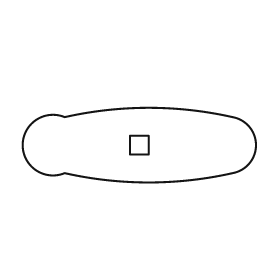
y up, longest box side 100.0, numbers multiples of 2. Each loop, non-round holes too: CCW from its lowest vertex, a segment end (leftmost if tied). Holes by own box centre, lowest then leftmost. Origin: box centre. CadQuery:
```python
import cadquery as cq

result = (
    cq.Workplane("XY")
    .moveTo(-32.0, -12.0)
    .threePointArc((4.0, -16.0), (40.0, -12.0))
    .threePointArc((50.0, 0.0), (40.0, 12.0))
    .threePointArc((4.0, 16.0), (-32.0, 12.0))
    .threePointArc((-50.0, 0.0), (-32.0, -12.0))
    .close()
    .moveTo(-4.0, -4.0)
    .lineTo(4.0, -4.0)
    .lineTo(4.0, 4.0)
    .lineTo(-4.0, 4.0)
    .close()
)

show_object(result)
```